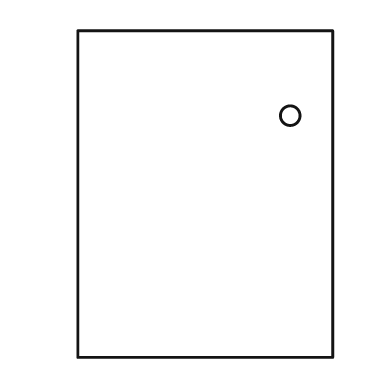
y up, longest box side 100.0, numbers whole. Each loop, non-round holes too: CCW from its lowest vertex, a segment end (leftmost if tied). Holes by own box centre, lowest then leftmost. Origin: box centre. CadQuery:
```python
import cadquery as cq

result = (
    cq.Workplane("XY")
    .moveTo(-39.0, -50.0)
    .lineTo(39.0, -50.0)
    .lineTo(39.0, 50.0)
    .lineTo(-39.0, 50.0)
    .close()
    .moveTo(26.0, 24.0)
    .circle(3.0)
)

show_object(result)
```